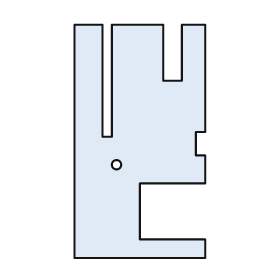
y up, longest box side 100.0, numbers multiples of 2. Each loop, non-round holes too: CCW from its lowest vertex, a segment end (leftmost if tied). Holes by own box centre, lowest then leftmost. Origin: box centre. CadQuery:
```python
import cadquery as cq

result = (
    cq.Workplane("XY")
    .moveTo(-28.0, -50.0)
    .lineTo(28.0, -50.0)
    .lineTo(28.0, -42.0)
    .lineTo(0.0, -42.0)
    .lineTo(0.0, -18.0)
    .lineTo(28.0, -18.0)
    .lineTo(28.0, -6.0)
    .lineTo(24.0, -6.0)
    .lineTo(24.0, 4.0)
    .lineTo(28.0, 4.0)
    .lineTo(28.0, 50.0)
    .lineTo(18.0, 50.0)
    .lineTo(18.0, 26.0)
    .lineTo(10.0, 26.0)
    .lineTo(10.0, 50.0)
    .lineTo(-12.0, 50.0)
    .lineTo(-12.0, 2.0)
    .lineTo(-16.0, 2.0)
    .lineTo(-16.0, 50.0)
    .lineTo(-28.0, 50.0)
    .close()
    .moveTo(-10.0, -10.0)
    .circle(2.0)
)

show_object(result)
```